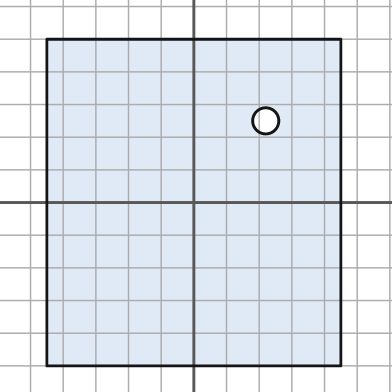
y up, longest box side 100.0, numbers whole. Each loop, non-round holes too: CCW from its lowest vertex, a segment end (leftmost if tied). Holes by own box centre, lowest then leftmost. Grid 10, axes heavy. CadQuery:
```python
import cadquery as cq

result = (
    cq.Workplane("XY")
    .moveTo(-45.0, -50.0)
    .lineTo(45.0, -50.0)
    .lineTo(45.0, 50.0)
    .lineTo(-45.0, 50.0)
    .close()
    .moveTo(22.0, 25.0)
    .circle(4.0)
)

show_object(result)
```